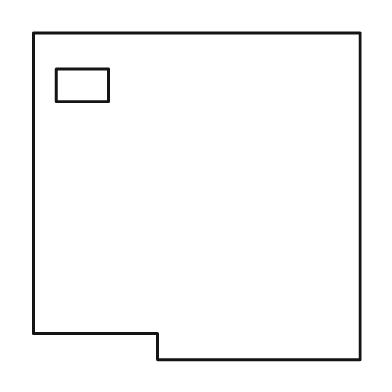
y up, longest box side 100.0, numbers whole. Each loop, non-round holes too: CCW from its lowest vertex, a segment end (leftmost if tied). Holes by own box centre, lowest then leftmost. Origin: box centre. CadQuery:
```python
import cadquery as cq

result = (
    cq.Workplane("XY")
    .moveTo(-12.0, -50.0)
    .lineTo(50.0, -50.0)
    .lineTo(50.0, 50.0)
    .lineTo(-50.0, 50.0)
    .lineTo(-50.0, -42.0)
    .lineTo(-12.0, -42.0)
    .close()
    .moveTo(-43.0, 29.0)
    .lineTo(-27.0, 29.0)
    .lineTo(-27.0, 39.0)
    .lineTo(-43.0, 39.0)
    .close()
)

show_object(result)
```